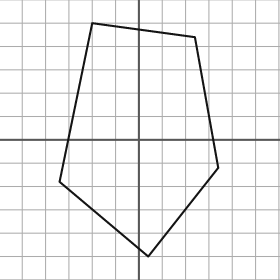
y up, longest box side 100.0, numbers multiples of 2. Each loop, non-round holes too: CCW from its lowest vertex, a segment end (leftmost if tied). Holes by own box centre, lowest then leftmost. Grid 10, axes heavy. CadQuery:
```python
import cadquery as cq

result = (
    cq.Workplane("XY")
    .moveTo(4.0, -50.0)
    .lineTo(34.0, -12.0)
    .lineTo(24.0, 44.0)
    .lineTo(-20.0, 50.0)
    .lineTo(-34.0, -18.0)
    .close()
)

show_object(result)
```